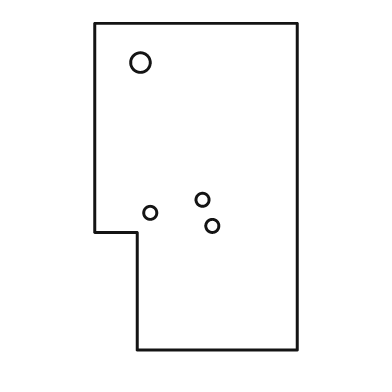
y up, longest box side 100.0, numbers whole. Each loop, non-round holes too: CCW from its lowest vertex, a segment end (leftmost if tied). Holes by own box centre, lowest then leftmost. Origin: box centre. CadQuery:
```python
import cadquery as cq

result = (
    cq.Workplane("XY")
    .moveTo(-18.0, -50.0)
    .lineTo(31.0, -50.0)
    .lineTo(31.0, 50.0)
    .lineTo(-31.0, 50.0)
    .lineTo(-31.0, -14.0)
    .lineTo(-18.0, -14.0)
    .close()
    .moveTo(5.0, -12.0)
    .circle(2.0)
    .moveTo(-14.0, -8.0)
    .circle(2.0)
    .moveTo(2.0, -4.0)
    .circle(2.0)
    .moveTo(-17.0, 38.0)
    .circle(3.0)
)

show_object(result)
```